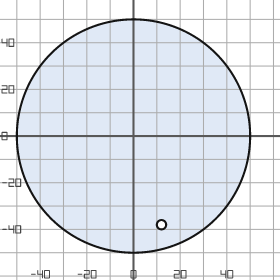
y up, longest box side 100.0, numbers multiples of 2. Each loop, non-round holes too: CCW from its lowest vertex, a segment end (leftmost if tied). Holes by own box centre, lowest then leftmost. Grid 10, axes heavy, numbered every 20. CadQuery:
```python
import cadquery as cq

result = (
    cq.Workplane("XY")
    .moveTo(0.0, 0.0)
    .circle(50.0)
    .moveTo(12.0, -38.0)
    .circle(2.0)
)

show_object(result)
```